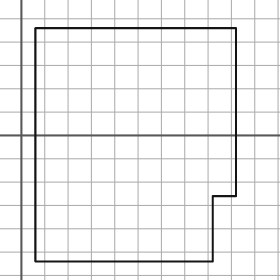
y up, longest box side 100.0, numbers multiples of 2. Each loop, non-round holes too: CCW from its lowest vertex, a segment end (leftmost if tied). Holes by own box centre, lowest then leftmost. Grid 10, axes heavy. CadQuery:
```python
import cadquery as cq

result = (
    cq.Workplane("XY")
    .moveTo(6.0, -54.0)
    .lineTo(82.0, -54.0)
    .lineTo(82.0, -26.0)
    .lineTo(92.0, -26.0)
    .lineTo(92.0, 46.0)
    .lineTo(6.0, 46.0)
    .close()
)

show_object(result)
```